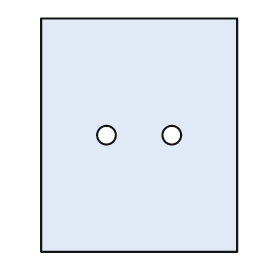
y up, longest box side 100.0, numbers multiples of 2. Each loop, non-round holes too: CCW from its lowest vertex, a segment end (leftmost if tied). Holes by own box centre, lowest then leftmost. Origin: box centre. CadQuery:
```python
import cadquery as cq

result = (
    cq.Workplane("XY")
    .moveTo(-42.0, -50.0)
    .lineTo(42.0, -50.0)
    .lineTo(42.0, 50.0)
    .lineTo(-42.0, 50.0)
    .close()
    .moveTo(-14.0, 0.0)
    .circle(4.0)
    .moveTo(14.0, 0.0)
    .circle(4.0)
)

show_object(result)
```